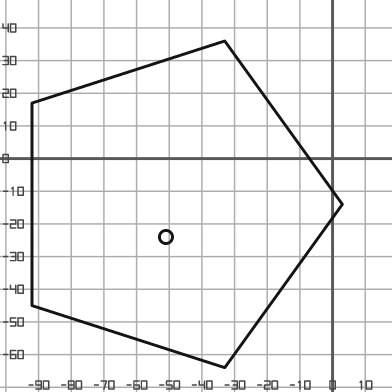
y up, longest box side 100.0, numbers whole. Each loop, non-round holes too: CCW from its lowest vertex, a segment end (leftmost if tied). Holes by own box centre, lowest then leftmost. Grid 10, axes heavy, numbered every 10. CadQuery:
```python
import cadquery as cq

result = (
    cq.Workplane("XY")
    .moveTo(-33.0, -64.0)
    .lineTo(3.0, -14.0)
    .lineTo(-33.0, 36.0)
    .lineTo(-92.0, 17.0)
    .lineTo(-92.0, -45.0)
    .close()
    .moveTo(-51.0, -24.0)
    .circle(2.0)
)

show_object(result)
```